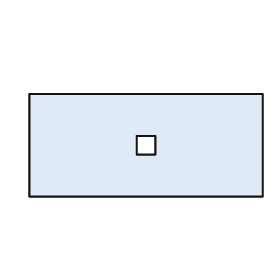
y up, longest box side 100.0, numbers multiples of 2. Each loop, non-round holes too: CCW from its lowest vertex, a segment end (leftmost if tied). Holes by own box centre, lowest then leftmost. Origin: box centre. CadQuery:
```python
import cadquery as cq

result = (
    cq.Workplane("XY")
    .moveTo(-50.0, -22.0)
    .lineTo(50.0, -22.0)
    .lineTo(50.0, 22.0)
    .lineTo(-50.0, 22.0)
    .close()
    .moveTo(-4.0, -4.0)
    .lineTo(4.0, -4.0)
    .lineTo(4.0, 4.0)
    .lineTo(-4.0, 4.0)
    .close()
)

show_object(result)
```